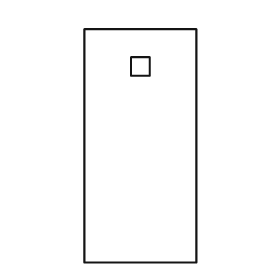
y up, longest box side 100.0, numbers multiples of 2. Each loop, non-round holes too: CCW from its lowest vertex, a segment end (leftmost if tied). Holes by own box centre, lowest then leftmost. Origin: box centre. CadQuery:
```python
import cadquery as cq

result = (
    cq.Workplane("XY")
    .moveTo(-24.0, -50.0)
    .lineTo(24.0, -50.0)
    .lineTo(24.0, 50.0)
    .lineTo(-24.0, 50.0)
    .close()
    .moveTo(-4.0, 30.0)
    .lineTo(4.0, 30.0)
    .lineTo(4.0, 38.0)
    .lineTo(-4.0, 38.0)
    .close()
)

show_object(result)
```